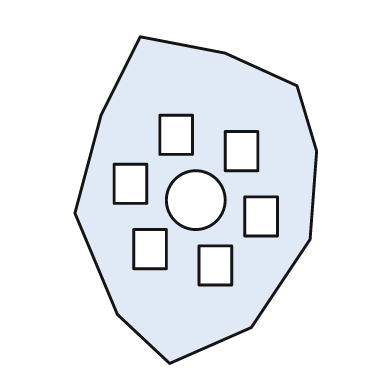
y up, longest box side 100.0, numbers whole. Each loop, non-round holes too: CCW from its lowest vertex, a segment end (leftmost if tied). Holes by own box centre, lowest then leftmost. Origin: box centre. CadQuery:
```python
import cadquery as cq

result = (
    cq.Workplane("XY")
    .moveTo(-8.0, -50.0)
    .lineTo(17.0, -39.0)
    .lineTo(35.0, -12.0)
    .lineTo(37.0, 15.0)
    .lineTo(31.0, 35.0)
    .lineTo(9.0, 45.0)
    .lineTo(-17.0, 50.0)
    .lineTo(-29.0, 26.0)
    .lineTo(-37.0, -4.0)
    .lineTo(-24.0, -35.0)
    .close()
    .moveTo(1.0, -26.0)
    .lineTo(11.0, -26.0)
    .lineTo(11.0, -14.0)
    .lineTo(1.0, -14.0)
    .close()
    .moveTo(-19.0, -21.0)
    .lineTo(-9.0, -21.0)
    .lineTo(-9.0, -9.0)
    .lineTo(-19.0, -9.0)
    .close()
    .moveTo(15.0, -11.0)
    .lineTo(25.0, -11.0)
    .lineTo(25.0, 1.0)
    .lineTo(15.0, 1.0)
    .close()
    .moveTo(0.0, 0.0)
    .circle(9.0)
    .moveTo(-25.0, -1.0)
    .lineTo(-15.0, -1.0)
    .lineTo(-15.0, 11.0)
    .lineTo(-25.0, 11.0)
    .close()
    .moveTo(9.0, 9.0)
    .lineTo(19.0, 9.0)
    .lineTo(19.0, 21.0)
    .lineTo(9.0, 21.0)
    .close()
    .moveTo(-11.0, 14.0)
    .lineTo(-1.0, 14.0)
    .lineTo(-1.0, 26.0)
    .lineTo(-11.0, 26.0)
    .close()
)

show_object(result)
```